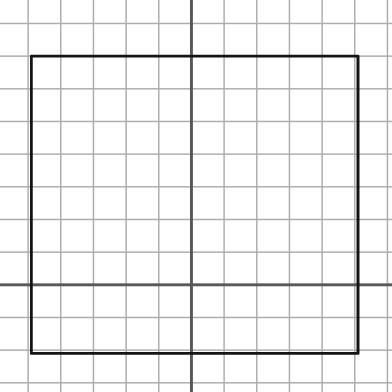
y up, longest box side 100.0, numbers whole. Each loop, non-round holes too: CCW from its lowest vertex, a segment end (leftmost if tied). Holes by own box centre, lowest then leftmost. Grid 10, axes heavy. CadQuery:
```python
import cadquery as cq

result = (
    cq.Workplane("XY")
    .moveTo(-49.0, -21.0)
    .lineTo(51.0, -21.0)
    .lineTo(51.0, 70.0)
    .lineTo(-49.0, 70.0)
    .close()
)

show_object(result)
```